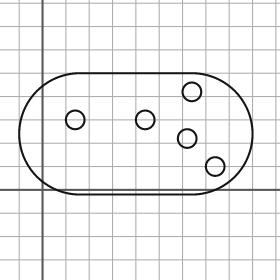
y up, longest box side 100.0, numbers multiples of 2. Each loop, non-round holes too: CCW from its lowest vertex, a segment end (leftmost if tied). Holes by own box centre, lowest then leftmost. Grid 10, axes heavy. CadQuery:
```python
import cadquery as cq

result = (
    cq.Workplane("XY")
    .moveTo(16.0, -2.0)
    .lineTo(64.0, -2.0)
    .threePointArc((90.0, 24.0), (64.0, 50.0))
    .lineTo(16.0, 50.0)
    .threePointArc((-10.0, 24.0), (16.0, -2.0))
    .close()
    .moveTo(74.0, 10.0)
    .circle(4.0)
    .moveTo(62.0, 22.0)
    .circle(4.0)
    .moveTo(14.0, 30.0)
    .circle(4.0)
    .moveTo(44.0, 30.0)
    .circle(4.0)
    .moveTo(64.0, 42.0)
    .circle(4.0)
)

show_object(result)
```